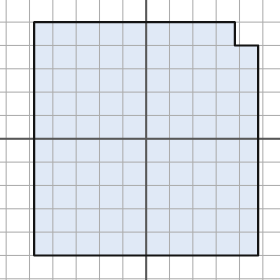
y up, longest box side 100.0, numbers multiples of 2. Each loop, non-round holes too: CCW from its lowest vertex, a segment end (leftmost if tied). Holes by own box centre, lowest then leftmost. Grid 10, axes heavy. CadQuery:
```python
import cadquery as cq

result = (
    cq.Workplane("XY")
    .moveTo(-48.0, -50.0)
    .lineTo(48.0, -50.0)
    .lineTo(48.0, 40.0)
    .lineTo(38.0, 40.0)
    .lineTo(38.0, 50.0)
    .lineTo(-48.0, 50.0)
    .close()
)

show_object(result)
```